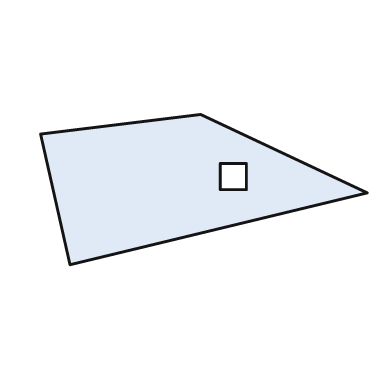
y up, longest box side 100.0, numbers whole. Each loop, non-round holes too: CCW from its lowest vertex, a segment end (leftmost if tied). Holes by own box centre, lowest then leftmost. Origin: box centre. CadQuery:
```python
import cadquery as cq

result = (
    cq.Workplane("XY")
    .moveTo(-41.0, -23.0)
    .lineTo(50.0, -1.0)
    .lineTo(-1.0, 23.0)
    .lineTo(-50.0, 17.0)
    .close()
    .moveTo(5.0, 0.0)
    .lineTo(13.0, 0.0)
    .lineTo(13.0, 8.0)
    .lineTo(5.0, 8.0)
    .close()
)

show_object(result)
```